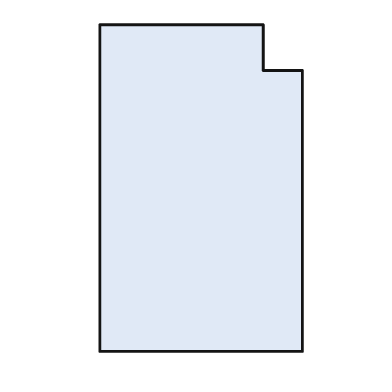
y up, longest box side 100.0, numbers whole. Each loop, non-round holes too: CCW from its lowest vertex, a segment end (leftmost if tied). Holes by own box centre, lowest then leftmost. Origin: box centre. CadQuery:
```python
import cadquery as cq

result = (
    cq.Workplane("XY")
    .moveTo(-31.0, -50.0)
    .lineTo(31.0, -50.0)
    .lineTo(31.0, 36.0)
    .lineTo(19.0, 36.0)
    .lineTo(19.0, 50.0)
    .lineTo(-31.0, 50.0)
    .close()
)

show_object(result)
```